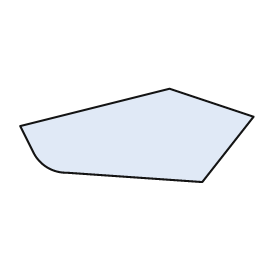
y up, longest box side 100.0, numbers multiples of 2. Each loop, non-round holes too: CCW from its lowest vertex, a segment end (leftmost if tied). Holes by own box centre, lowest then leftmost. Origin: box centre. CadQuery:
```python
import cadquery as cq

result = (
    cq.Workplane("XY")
    .moveTo(28.0, -20.0)
    .lineTo(50.0, 8.0)
    .lineTo(14.0, 20.0)
    .lineTo(-50.0, 4.0)
    .lineTo(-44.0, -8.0)
    .threePointArc((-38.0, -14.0), (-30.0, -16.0))
    .close()
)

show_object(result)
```